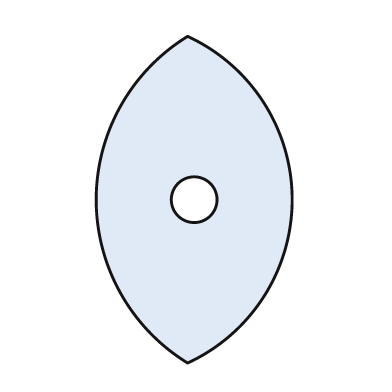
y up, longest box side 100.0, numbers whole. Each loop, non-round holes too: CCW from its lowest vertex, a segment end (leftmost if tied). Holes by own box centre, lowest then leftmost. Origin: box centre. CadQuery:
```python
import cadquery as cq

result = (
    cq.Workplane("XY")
    .moveTo(-2.0, -50.0)
    .threePointArc((30.0, 0.0), (-2.0, 50.0))
    .threePointArc((-30.0, 0.0), (-2.0, -50.0))
    .close()
    .moveTo(0.0, 0.0)
    .circle(7.0)
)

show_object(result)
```